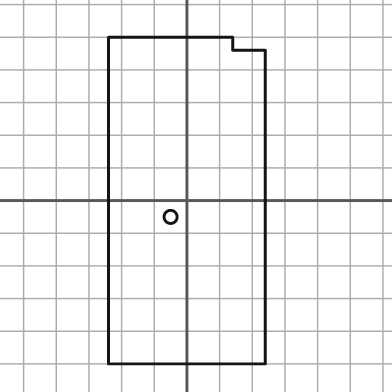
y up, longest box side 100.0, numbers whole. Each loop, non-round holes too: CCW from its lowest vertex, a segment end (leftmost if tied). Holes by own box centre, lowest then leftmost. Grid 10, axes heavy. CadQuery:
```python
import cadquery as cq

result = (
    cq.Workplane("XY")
    .moveTo(-24.0, -50.0)
    .lineTo(24.0, -50.0)
    .lineTo(24.0, 46.0)
    .lineTo(14.0, 46.0)
    .lineTo(14.0, 50.0)
    .lineTo(-24.0, 50.0)
    .close()
    .moveTo(-5.0, -5.0)
    .circle(2.0)
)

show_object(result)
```